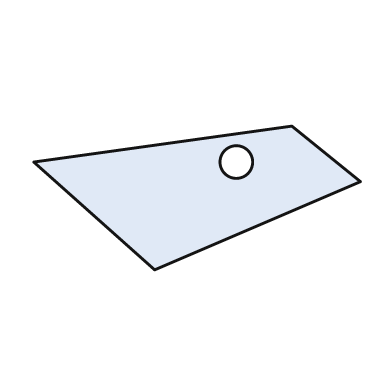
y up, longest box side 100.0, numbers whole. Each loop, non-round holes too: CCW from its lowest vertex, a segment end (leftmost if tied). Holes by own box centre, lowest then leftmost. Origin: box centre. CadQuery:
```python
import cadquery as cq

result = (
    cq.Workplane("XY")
    .moveTo(-13.0, -22.0)
    .lineTo(50.0, 5.0)
    .lineTo(29.0, 22.0)
    .lineTo(-50.0, 11.0)
    .close()
    .moveTo(12.0, 11.0)
    .circle(5.0)
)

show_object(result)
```